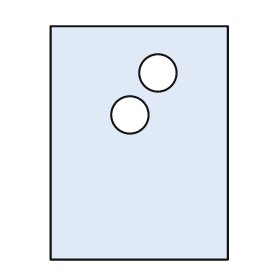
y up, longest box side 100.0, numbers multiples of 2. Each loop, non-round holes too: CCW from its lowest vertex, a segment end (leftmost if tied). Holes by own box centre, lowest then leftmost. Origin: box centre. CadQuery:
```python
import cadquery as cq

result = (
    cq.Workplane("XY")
    .moveTo(-38.0, -50.0)
    .lineTo(38.0, -50.0)
    .lineTo(38.0, 50.0)
    .lineTo(-38.0, 50.0)
    .close()
    .moveTo(-4.0, 12.0)
    .circle(8.0)
    .moveTo(8.0, 30.0)
    .circle(8.0)
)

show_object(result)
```